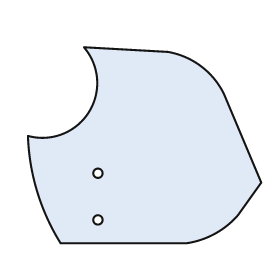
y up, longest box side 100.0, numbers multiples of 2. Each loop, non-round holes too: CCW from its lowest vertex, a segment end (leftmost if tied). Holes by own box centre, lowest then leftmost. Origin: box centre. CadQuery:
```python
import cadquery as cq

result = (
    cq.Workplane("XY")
    .moveTo(-36.0, -42.0)
    .lineTo(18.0, -42.0)
    .threePointArc((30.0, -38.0), (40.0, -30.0))
    .lineTo(50.0, -16.0)
    .lineTo(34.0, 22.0)
    .threePointArc((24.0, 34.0), (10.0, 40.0))
    .lineTo(-26.0, 42.0)
    .threePointArc((-24.0, 14.0), (-50.0, 4.0))
    .threePointArc((-46.0, -20.0), (-36.0, -42.0))
    .close()
    .moveTo(-20.0, -32.0)
    .circle(2.0)
    .moveTo(-20.0, -12.0)
    .circle(2.0)
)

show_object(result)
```